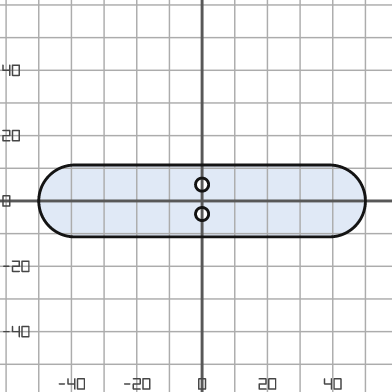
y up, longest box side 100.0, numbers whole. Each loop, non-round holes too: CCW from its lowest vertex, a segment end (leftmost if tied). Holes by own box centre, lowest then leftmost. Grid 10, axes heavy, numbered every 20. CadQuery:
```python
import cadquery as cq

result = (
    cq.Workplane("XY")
    .moveTo(-39.0, -11.0)
    .lineTo(39.0, -11.0)
    .threePointArc((50.0, 0.0), (39.0, 11.0))
    .lineTo(-39.0, 11.0)
    .threePointArc((-50.0, 0.0), (-39.0, -11.0))
    .close()
    .moveTo(0.0, -4.0)
    .circle(2.0)
    .moveTo(0.0, 5.0)
    .circle(2.0)
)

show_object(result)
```